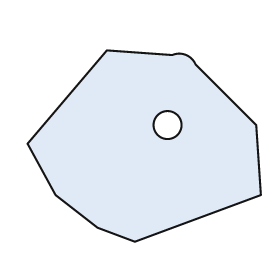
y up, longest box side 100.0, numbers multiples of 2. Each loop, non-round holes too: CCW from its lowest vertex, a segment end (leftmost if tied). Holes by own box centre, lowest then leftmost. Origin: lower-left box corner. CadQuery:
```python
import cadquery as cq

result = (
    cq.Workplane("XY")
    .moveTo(46.0, 0.0)
    .lineTo(100.0, 20.0)
    .lineTo(98.0, 50.0)
    .lineTo(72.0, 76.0)
    .threePointArc((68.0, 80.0), (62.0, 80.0))
    .lineTo(34.0, 82.0)
    .lineTo(0.0, 42.0)
    .lineTo(12.0, 20.0)
    .lineTo(30.0, 6.0)
    .close()
    .moveTo(60.0, 50.0)
    .circle(6.0)
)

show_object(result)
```